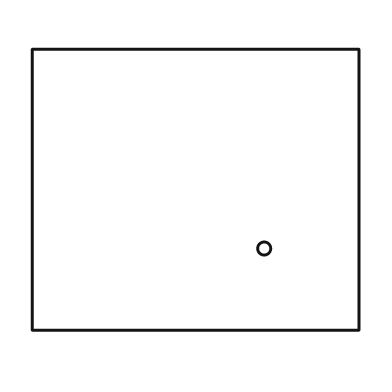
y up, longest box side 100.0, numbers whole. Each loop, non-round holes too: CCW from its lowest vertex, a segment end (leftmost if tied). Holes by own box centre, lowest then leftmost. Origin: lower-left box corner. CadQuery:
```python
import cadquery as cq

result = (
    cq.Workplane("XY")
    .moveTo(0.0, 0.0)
    .lineTo(100.0, 0.0)
    .lineTo(100.0, 86.0)
    .lineTo(0.0, 86.0)
    .close()
    .moveTo(71.0, 25.0)
    .circle(2.0)
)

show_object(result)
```